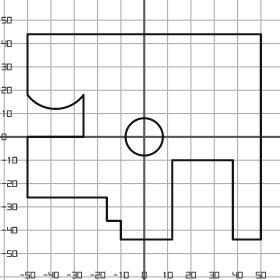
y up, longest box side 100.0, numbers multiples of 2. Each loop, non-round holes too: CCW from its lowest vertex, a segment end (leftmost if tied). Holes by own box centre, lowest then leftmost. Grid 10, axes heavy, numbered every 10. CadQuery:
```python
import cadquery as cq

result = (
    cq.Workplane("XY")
    .moveTo(-10.0, -44.0)
    .lineTo(12.0, -44.0)
    .lineTo(12.0, -10.0)
    .lineTo(38.0, -10.0)
    .lineTo(38.0, -44.0)
    .lineTo(50.0, -44.0)
    .lineTo(50.0, 44.0)
    .lineTo(-50.0, 44.0)
    .lineTo(-50.0, 18.0)
    .threePointArc((-38.0, 12.0), (-26.0, 18.0))
    .lineTo(-26.0, 0.0)
    .lineTo(-50.0, 0.0)
    .lineTo(-50.0, -26.0)
    .lineTo(-16.0, -26.0)
    .lineTo(-16.0, -36.0)
    .lineTo(-10.0, -36.0)
    .close()
    .moveTo(0.0, 0.0)
    .circle(8.0)
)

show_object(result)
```